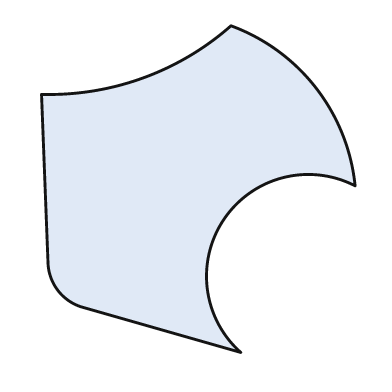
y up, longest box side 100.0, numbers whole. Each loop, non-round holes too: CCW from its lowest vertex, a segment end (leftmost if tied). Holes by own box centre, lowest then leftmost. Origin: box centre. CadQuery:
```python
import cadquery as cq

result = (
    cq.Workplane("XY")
    .moveTo(13.0, -50.0)
    .threePointArc((8.0, -9.0), (48.0, 1.0))
    .threePointArc((36.0, 31.0), (10.0, 50.0))
    .threePointArc((-17.0, 34.0), (-48.0, 29.0))
    .lineTo(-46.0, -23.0)
    .threePointArc((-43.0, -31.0), (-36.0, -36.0))
    .close()
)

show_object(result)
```